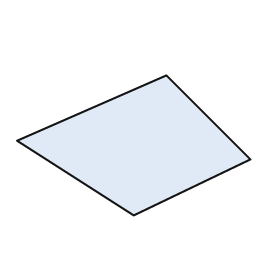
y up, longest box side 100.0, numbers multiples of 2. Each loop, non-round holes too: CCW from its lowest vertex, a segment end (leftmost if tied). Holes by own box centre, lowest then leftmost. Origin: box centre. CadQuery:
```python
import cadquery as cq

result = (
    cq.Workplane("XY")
    .moveTo(0.0, -30.0)
    .lineTo(50.0, -6.0)
    .lineTo(14.0, 30.0)
    .lineTo(-50.0, 2.0)
    .close()
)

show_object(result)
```